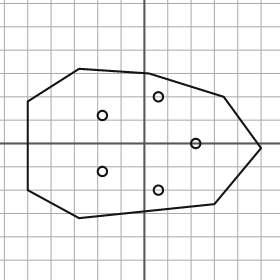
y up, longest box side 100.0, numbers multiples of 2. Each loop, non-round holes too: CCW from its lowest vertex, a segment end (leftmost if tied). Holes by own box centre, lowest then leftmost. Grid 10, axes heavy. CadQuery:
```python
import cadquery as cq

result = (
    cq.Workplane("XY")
    .moveTo(-28.0, -32.0)
    .lineTo(30.0, -26.0)
    .lineTo(50.0, -2.0)
    .lineTo(34.0, 20.0)
    .lineTo(2.0, 30.0)
    .lineTo(-28.0, 32.0)
    .lineTo(-50.0, 18.0)
    .lineTo(-50.0, -20.0)
    .close()
    .moveTo(6.0, -20.0)
    .circle(2.0)
    .moveTo(-18.0, -12.0)
    .circle(2.0)
    .moveTo(22.0, 0.0)
    .circle(2.0)
    .moveTo(-18.0, 12.0)
    .circle(2.0)
    .moveTo(6.0, 20.0)
    .circle(2.0)
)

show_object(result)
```